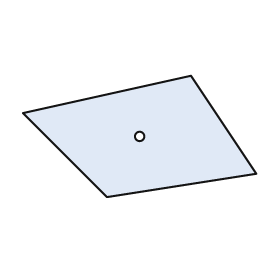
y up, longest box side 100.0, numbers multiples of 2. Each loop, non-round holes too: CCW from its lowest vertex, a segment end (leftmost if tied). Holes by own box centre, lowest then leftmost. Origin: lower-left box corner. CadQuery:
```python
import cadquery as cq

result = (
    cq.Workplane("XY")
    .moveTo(36.0, 0.0)
    .lineTo(100.0, 10.0)
    .lineTo(72.0, 52.0)
    .lineTo(0.0, 36.0)
    .close()
    .moveTo(50.0, 26.0)
    .circle(2.0)
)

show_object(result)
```